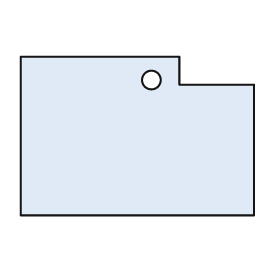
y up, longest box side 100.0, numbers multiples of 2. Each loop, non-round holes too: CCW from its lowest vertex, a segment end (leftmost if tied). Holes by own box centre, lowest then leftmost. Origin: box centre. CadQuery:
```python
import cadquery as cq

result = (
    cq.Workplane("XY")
    .moveTo(-50.0, -34.0)
    .lineTo(50.0, -34.0)
    .lineTo(50.0, 22.0)
    .lineTo(18.0, 22.0)
    .lineTo(18.0, 34.0)
    .lineTo(-50.0, 34.0)
    .close()
    .moveTo(6.0, 24.0)
    .circle(4.0)
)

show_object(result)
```